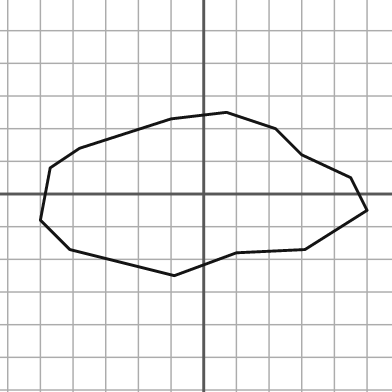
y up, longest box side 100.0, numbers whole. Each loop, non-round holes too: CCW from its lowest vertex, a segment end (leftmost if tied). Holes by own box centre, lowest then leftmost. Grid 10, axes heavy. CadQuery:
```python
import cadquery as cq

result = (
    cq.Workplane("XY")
    .moveTo(-9.0, -25.0)
    .lineTo(10.0, -18.0)
    .lineTo(31.0, -17.0)
    .lineTo(50.0, -5.0)
    .lineTo(45.0, 5.0)
    .lineTo(30.0, 12.0)
    .lineTo(22.0, 20.0)
    .lineTo(7.0, 25.0)
    .lineTo(-10.0, 23.0)
    .lineTo(-38.0, 14.0)
    .lineTo(-47.0, 8.0)
    .lineTo(-50.0, -8.0)
    .lineTo(-41.0, -17.0)
    .close()
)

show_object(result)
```